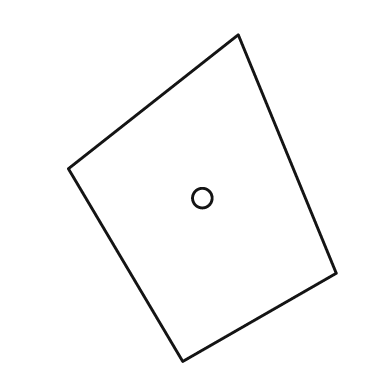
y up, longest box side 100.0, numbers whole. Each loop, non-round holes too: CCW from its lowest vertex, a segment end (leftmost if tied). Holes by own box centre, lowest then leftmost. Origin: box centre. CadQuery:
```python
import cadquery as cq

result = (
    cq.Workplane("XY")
    .moveTo(-6.0, -50.0)
    .lineTo(41.0, -23.0)
    .lineTo(11.0, 50.0)
    .lineTo(-41.0, 9.0)
    .close()
    .moveTo(0.0, 0.0)
    .circle(3.0)
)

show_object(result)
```